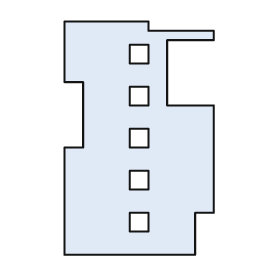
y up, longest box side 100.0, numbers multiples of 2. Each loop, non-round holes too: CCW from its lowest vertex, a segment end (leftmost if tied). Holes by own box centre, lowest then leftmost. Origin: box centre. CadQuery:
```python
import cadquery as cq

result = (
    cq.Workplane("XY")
    .moveTo(-32.0, -50.0)
    .lineTo(24.0, -50.0)
    .lineTo(24.0, -32.0)
    .lineTo(32.0, -32.0)
    .lineTo(32.0, 14.0)
    .lineTo(12.0, 14.0)
    .lineTo(12.0, 42.0)
    .lineTo(32.0, 42.0)
    .lineTo(32.0, 46.0)
    .lineTo(4.0, 46.0)
    .lineTo(4.0, 50.0)
    .lineTo(-32.0, 50.0)
    .lineTo(-32.0, 24.0)
    .lineTo(-24.0, 24.0)
    .lineTo(-24.0, -4.0)
    .lineTo(-32.0, -4.0)
    .close()
    .moveTo(-4.0, -40.0)
    .lineTo(4.0, -40.0)
    .lineTo(4.0, -32.0)
    .lineTo(-4.0, -32.0)
    .close()
    .moveTo(-4.0, -22.0)
    .lineTo(4.0, -22.0)
    .lineTo(4.0, -14.0)
    .lineTo(-4.0, -14.0)
    .close()
    .moveTo(-4.0, -4.0)
    .lineTo(4.0, -4.0)
    .lineTo(4.0, 4.0)
    .lineTo(-4.0, 4.0)
    .close()
    .moveTo(-4.0, 14.0)
    .lineTo(4.0, 14.0)
    .lineTo(4.0, 22.0)
    .lineTo(-4.0, 22.0)
    .close()
    .moveTo(-4.0, 32.0)
    .lineTo(4.0, 32.0)
    .lineTo(4.0, 40.0)
    .lineTo(-4.0, 40.0)
    .close()
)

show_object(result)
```